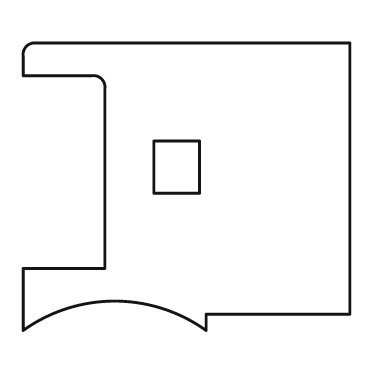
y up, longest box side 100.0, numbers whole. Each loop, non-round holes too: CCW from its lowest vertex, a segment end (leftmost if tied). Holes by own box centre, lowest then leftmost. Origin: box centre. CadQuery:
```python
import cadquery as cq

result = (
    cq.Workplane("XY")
    .moveTo(-50.0, -44.0)
    .threePointArc((-22.0, -35.0), (6.0, -44.0))
    .lineTo(6.0, -39.0)
    .lineTo(50.0, -39.0)
    .lineTo(50.0, 44.0)
    .lineTo(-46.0, 44.0)
    .threePointArc((-49.0, 43.0), (-50.0, 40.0))
    .lineTo(-50.0, 34.0)
    .lineTo(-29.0, 34.0)
    .threePointArc((-26.0, 33.0), (-25.0, 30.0))
    .lineTo(-25.0, -25.0)
    .lineTo(-50.0, -25.0)
    .close()
    .moveTo(-10.0, -2.0)
    .lineTo(4.0, -2.0)
    .lineTo(4.0, 14.0)
    .lineTo(-10.0, 14.0)
    .close()
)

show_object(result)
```